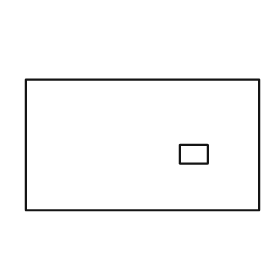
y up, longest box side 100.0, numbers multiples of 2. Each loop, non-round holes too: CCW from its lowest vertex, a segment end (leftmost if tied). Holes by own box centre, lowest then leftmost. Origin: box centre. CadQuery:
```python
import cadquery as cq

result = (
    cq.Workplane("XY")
    .moveTo(-50.0, -28.0)
    .lineTo(50.0, -28.0)
    .lineTo(50.0, 28.0)
    .lineTo(-50.0, 28.0)
    .close()
    .moveTo(16.0, -8.0)
    .lineTo(28.0, -8.0)
    .lineTo(28.0, 0.0)
    .lineTo(16.0, 0.0)
    .close()
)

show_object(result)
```